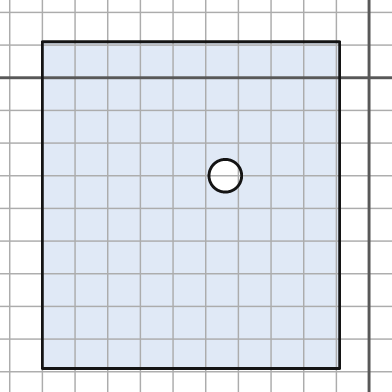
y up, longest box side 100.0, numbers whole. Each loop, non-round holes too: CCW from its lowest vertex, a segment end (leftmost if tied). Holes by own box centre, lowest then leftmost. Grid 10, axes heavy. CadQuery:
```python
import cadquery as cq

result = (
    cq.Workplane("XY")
    .moveTo(-100.0, -89.0)
    .lineTo(-9.0, -89.0)
    .lineTo(-9.0, 11.0)
    .lineTo(-100.0, 11.0)
    .close()
    .moveTo(-44.0, -30.0)
    .circle(5.0)
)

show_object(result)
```